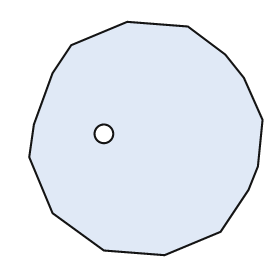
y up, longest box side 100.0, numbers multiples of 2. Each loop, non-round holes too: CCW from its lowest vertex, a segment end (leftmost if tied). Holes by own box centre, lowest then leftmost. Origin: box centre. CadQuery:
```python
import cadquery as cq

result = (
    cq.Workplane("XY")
    .moveTo(8.0, -50.0)
    .lineTo(32.0, -40.0)
    .lineTo(44.0, -22.0)
    .lineTo(48.0, -12.0)
    .lineTo(50.0, 8.0)
    .lineTo(42.0, 26.0)
    .lineTo(34.0, 36.0)
    .lineTo(18.0, 48.0)
    .lineTo(-8.0, 50.0)
    .lineTo(-32.0, 40.0)
    .lineTo(-40.0, 28.0)
    .lineTo(-48.0, 6.0)
    .lineTo(-50.0, -8.0)
    .lineTo(-40.0, -32.0)
    .lineTo(-18.0, -48.0)
    .close()
    .moveTo(-18.0, 2.0)
    .circle(4.0)
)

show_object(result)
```